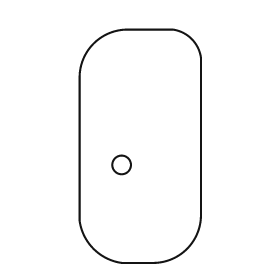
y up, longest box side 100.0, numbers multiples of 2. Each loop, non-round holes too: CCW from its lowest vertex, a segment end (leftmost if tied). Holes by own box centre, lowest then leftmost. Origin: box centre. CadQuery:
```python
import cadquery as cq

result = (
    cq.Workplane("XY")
    .moveTo(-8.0, -50.0)
    .lineTo(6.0, -50.0)
    .threePointArc((20.0, -44.0), (26.0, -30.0))
    .lineTo(26.0, 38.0)
    .threePointArc((22.0, 46.0), (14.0, 50.0))
    .lineTo(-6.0, 50.0)
    .threePointArc((-20.0, 44.0), (-26.0, 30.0))
    .lineTo(-26.0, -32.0)
    .threePointArc((-20.0, -44.0), (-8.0, -50.0))
    .close()
    .moveTo(-8.0, -8.0)
    .circle(4.0)
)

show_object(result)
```